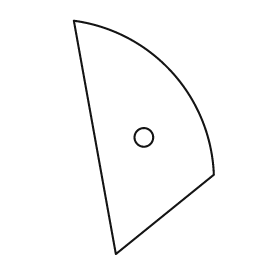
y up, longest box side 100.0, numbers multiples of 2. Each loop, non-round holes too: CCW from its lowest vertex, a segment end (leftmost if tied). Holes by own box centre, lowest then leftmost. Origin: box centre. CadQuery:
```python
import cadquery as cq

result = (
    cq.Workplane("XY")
    .moveTo(-12.0, -50.0)
    .lineTo(30.0, -16.0)
    .threePointArc((12.0, 28.0), (-30.0, 50.0))
    .close()
    .moveTo(0.0, 0.0)
    .circle(4.0)
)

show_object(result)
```